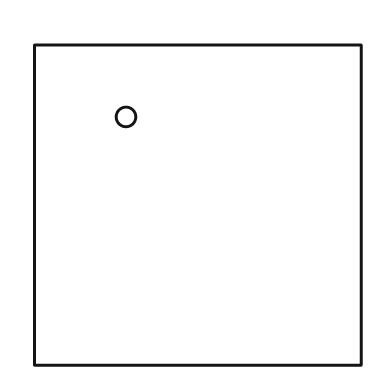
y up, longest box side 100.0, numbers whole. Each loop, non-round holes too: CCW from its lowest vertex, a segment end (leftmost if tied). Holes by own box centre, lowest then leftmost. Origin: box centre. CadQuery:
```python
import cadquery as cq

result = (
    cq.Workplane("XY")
    .moveTo(-50.0, -49.0)
    .lineTo(50.0, -49.0)
    .lineTo(50.0, 49.0)
    .lineTo(-50.0, 49.0)
    .close()
    .moveTo(-22.0, 27.0)
    .circle(3.0)
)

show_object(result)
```